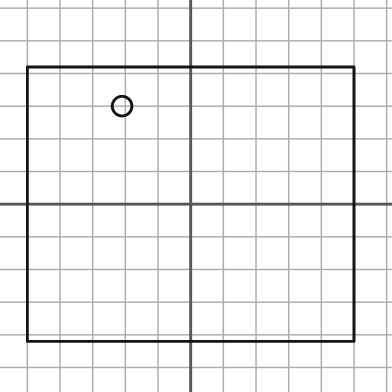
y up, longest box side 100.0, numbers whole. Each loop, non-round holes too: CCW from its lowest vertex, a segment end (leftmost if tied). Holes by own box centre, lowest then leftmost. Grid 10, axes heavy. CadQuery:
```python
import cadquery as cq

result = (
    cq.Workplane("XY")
    .moveTo(-50.0, -42.0)
    .lineTo(50.0, -42.0)
    .lineTo(50.0, 42.0)
    .lineTo(-50.0, 42.0)
    .close()
    .moveTo(-21.0, 30.0)
    .circle(3.0)
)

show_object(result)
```